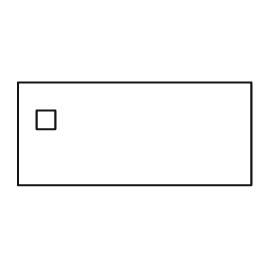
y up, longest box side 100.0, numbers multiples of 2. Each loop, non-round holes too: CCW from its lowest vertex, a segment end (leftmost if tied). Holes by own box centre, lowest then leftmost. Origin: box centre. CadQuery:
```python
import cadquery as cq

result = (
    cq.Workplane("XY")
    .moveTo(-50.0, -22.0)
    .lineTo(50.0, -22.0)
    .lineTo(50.0, 22.0)
    .lineTo(-50.0, 22.0)
    .close()
    .moveTo(-42.0, 2.0)
    .lineTo(-34.0, 2.0)
    .lineTo(-34.0, 10.0)
    .lineTo(-42.0, 10.0)
    .close()
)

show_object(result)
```